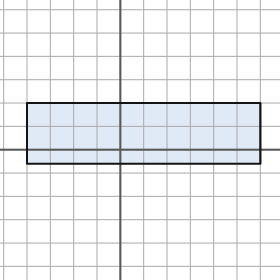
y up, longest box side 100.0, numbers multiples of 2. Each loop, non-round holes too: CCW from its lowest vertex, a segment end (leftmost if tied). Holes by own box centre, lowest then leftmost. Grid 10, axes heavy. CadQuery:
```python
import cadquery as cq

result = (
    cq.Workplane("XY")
    .moveTo(-40.0, -6.0)
    .lineTo(60.0, -6.0)
    .lineTo(60.0, 20.0)
    .lineTo(-40.0, 20.0)
    .close()
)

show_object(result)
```